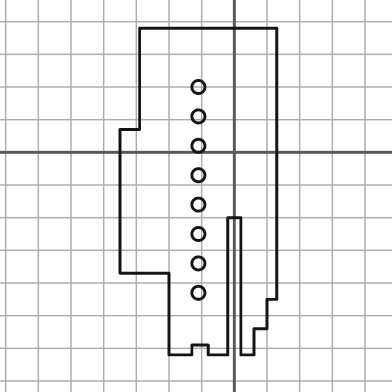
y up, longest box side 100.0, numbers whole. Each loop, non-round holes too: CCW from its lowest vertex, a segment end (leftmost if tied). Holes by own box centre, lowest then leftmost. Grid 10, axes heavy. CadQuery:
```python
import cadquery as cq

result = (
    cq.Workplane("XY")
    .moveTo(-20.0, -62.0)
    .lineTo(-13.0, -62.0)
    .lineTo(-13.0, -59.0)
    .lineTo(-8.0, -59.0)
    .lineTo(-8.0, -62.0)
    .lineTo(-2.0, -62.0)
    .lineTo(-2.0, -20.0)
    .lineTo(2.0, -20.0)
    .lineTo(2.0, -62.0)
    .lineTo(6.0, -62.0)
    .lineTo(6.0, -54.0)
    .lineTo(10.0, -54.0)
    .lineTo(10.0, -45.0)
    .lineTo(13.0, -45.0)
    .lineTo(13.0, 38.0)
    .lineTo(-29.0, 38.0)
    .lineTo(-29.0, 7.0)
    .lineTo(-35.0, 7.0)
    .lineTo(-35.0, -37.0)
    .lineTo(-20.0, -37.0)
    .close()
    .moveTo(-11.0, -43.0)
    .circle(2.0)
    .moveTo(-11.0, -34.0)
    .circle(2.0)
    .moveTo(-11.0, -25.0)
    .circle(2.0)
    .moveTo(-11.0, -16.0)
    .circle(2.0)
    .moveTo(-11.0, -7.0)
    .circle(2.0)
    .moveTo(-11.0, 2.0)
    .circle(2.0)
    .moveTo(-11.0, 11.0)
    .circle(2.0)
    .moveTo(-11.0, 20.0)
    .circle(2.0)
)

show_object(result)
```